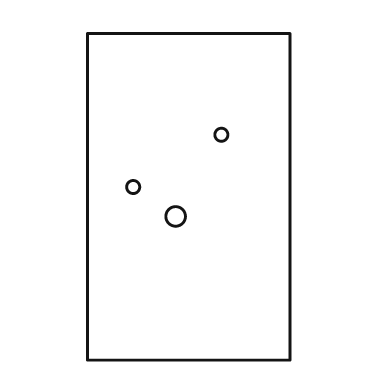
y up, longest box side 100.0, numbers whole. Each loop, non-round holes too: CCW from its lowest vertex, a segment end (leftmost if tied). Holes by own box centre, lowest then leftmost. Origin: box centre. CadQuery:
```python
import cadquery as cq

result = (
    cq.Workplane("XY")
    .moveTo(-31.0, -50.0)
    .lineTo(31.0, -50.0)
    .lineTo(31.0, 50.0)
    .lineTo(-31.0, 50.0)
    .close()
    .moveTo(-4.0, -6.0)
    .circle(3.0)
    .moveTo(-17.0, 3.0)
    .circle(2.0)
    .moveTo(10.0, 19.0)
    .circle(2.0)
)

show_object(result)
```